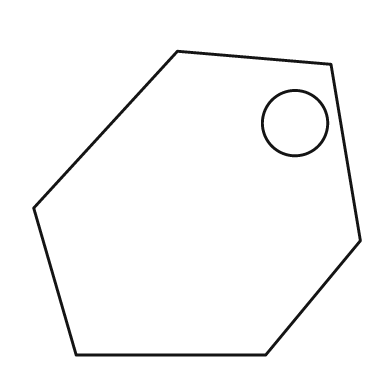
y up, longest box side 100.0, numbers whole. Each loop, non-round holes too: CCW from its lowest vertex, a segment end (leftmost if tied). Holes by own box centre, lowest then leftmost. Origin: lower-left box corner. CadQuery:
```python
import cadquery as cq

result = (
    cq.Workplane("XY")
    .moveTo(13.0, 0.0)
    .lineTo(71.0, 0.0)
    .lineTo(100.0, 35.0)
    .lineTo(91.0, 89.0)
    .lineTo(44.0, 93.0)
    .lineTo(0.0, 45.0)
    .close()
    .moveTo(80.0, 71.0)
    .circle(10.0)
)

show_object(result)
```